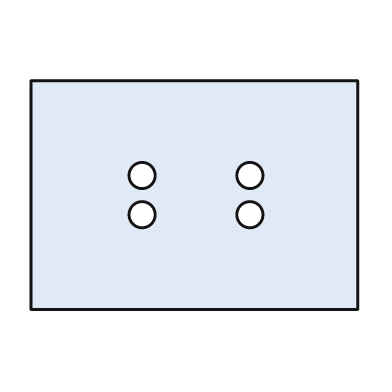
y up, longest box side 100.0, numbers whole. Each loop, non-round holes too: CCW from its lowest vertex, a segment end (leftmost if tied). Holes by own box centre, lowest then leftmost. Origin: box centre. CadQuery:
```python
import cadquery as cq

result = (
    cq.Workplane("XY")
    .moveTo(-50.0, -35.0)
    .lineTo(50.0, -35.0)
    .lineTo(50.0, 35.0)
    .lineTo(-50.0, 35.0)
    .close()
    .moveTo(-16.0, -6.0)
    .circle(4.0)
    .moveTo(17.0, -6.0)
    .circle(4.0)
    .moveTo(-16.0, 6.0)
    .circle(4.0)
    .moveTo(17.0, 6.0)
    .circle(4.0)
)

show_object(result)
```